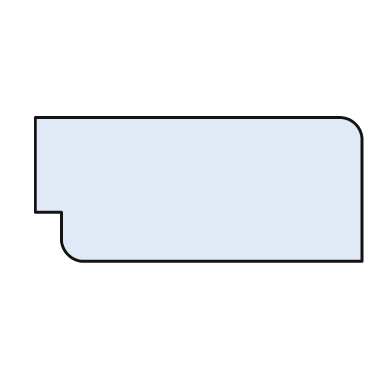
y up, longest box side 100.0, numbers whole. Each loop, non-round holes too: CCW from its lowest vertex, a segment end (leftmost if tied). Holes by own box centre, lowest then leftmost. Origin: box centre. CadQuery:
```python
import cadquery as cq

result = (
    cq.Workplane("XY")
    .moveTo(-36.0, -22.0)
    .lineTo(50.0, -22.0)
    .lineTo(50.0, 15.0)
    .threePointArc((48.0, 20.0), (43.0, 22.0))
    .lineTo(-50.0, 22.0)
    .lineTo(-50.0, -7.0)
    .lineTo(-42.0, -7.0)
    .lineTo(-42.0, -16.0)
    .threePointArc((-40.0, -20.0), (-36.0, -22.0))
    .close()
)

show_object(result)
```